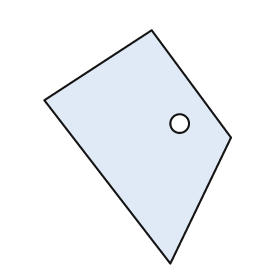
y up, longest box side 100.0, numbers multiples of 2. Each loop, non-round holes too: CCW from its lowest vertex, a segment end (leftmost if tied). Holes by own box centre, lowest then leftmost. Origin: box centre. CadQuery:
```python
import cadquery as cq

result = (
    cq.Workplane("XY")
    .moveTo(14.0, -50.0)
    .lineTo(40.0, 4.0)
    .lineTo(6.0, 50.0)
    .lineTo(-40.0, 20.0)
    .close()
    .moveTo(18.0, 10.0)
    .circle(4.0)
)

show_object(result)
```